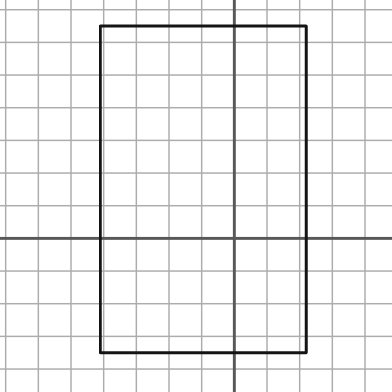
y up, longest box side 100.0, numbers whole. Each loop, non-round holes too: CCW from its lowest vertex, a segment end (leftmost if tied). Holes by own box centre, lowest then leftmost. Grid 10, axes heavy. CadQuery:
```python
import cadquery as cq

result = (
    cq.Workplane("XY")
    .moveTo(-41.0, -35.0)
    .lineTo(22.0, -35.0)
    .lineTo(22.0, 65.0)
    .lineTo(-41.0, 65.0)
    .close()
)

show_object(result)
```